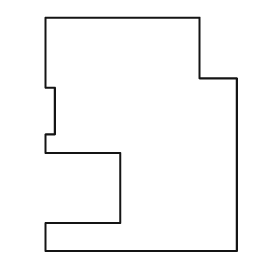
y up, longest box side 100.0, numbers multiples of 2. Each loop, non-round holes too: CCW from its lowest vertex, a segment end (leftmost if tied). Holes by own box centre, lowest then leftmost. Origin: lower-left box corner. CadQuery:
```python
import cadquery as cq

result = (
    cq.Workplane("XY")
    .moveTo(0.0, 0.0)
    .lineTo(82.0, 0.0)
    .lineTo(82.0, 74.0)
    .lineTo(66.0, 74.0)
    .lineTo(66.0, 100.0)
    .lineTo(0.0, 100.0)
    .lineTo(0.0, 70.0)
    .lineTo(4.0, 70.0)
    .lineTo(4.0, 50.0)
    .lineTo(0.0, 50.0)
    .lineTo(0.0, 42.0)
    .lineTo(32.0, 42.0)
    .lineTo(32.0, 12.0)
    .lineTo(0.0, 12.0)
    .close()
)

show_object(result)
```